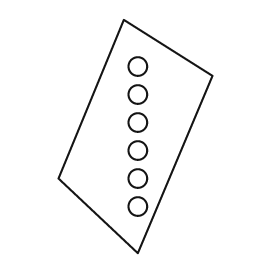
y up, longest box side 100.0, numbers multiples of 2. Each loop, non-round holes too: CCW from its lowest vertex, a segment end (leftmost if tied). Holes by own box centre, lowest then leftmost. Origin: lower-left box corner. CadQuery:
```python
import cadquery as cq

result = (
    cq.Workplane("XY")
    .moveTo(34.0, 0.0)
    .lineTo(66.0, 76.0)
    .lineTo(28.0, 100.0)
    .lineTo(0.0, 32.0)
    .close()
    .moveTo(34.0, 20.0)
    .circle(4.0)
    .moveTo(34.0, 32.0)
    .circle(4.0)
    .moveTo(34.0, 44.0)
    .circle(4.0)
    .moveTo(34.0, 56.0)
    .circle(4.0)
    .moveTo(34.0, 68.0)
    .circle(4.0)
    .moveTo(34.0, 80.0)
    .circle(4.0)
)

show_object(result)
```